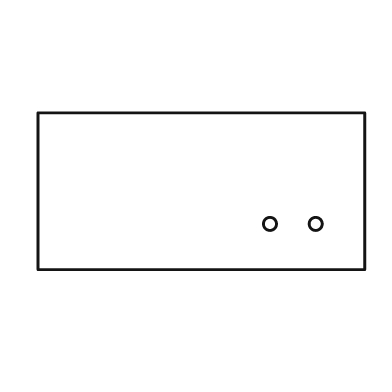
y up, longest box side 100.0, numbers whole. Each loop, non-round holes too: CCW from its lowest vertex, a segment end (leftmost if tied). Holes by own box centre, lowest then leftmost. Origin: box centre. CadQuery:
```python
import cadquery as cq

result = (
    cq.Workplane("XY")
    .moveTo(-50.0, -24.0)
    .lineTo(50.0, -24.0)
    .lineTo(50.0, 24.0)
    .lineTo(-50.0, 24.0)
    .close()
    .moveTo(21.0, -10.0)
    .circle(2.0)
    .moveTo(35.0, -10.0)
    .circle(2.0)
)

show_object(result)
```